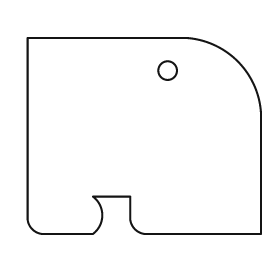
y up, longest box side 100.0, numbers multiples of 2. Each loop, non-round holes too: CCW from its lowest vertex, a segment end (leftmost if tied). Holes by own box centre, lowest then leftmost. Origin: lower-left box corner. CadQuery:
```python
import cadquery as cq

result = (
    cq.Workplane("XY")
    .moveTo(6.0, 0.0)
    .lineTo(28.0, 0.0)
    .threePointArc((32.0, 8.0), (28.0, 16.0))
    .lineTo(44.0, 16.0)
    .lineTo(44.0, 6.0)
    .threePointArc((46.0, 2.0), (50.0, 0.0))
    .lineTo(100.0, 0.0)
    .lineTo(100.0, 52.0)
    .threePointArc((90.0, 74.0), (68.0, 84.0))
    .lineTo(0.0, 84.0)
    .lineTo(0.0, 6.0)
    .threePointArc((2.0, 2.0), (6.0, 0.0))
    .close()
    .moveTo(60.0, 70.0)
    .circle(4.0)
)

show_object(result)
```